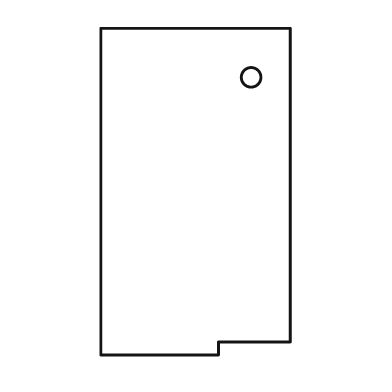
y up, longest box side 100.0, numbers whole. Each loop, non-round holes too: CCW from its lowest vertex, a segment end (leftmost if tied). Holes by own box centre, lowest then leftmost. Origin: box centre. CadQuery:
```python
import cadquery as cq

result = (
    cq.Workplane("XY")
    .moveTo(-29.0, -50.0)
    .lineTo(7.0, -50.0)
    .lineTo(7.0, -46.0)
    .lineTo(29.0, -46.0)
    .lineTo(29.0, 50.0)
    .lineTo(-29.0, 50.0)
    .close()
    .moveTo(17.0, 35.0)
    .circle(3.0)
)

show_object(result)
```